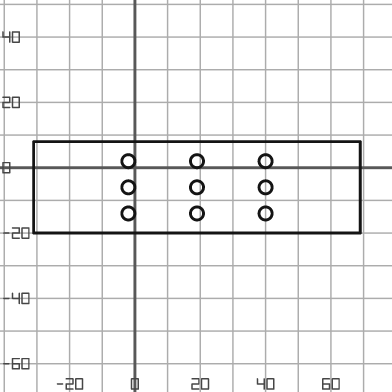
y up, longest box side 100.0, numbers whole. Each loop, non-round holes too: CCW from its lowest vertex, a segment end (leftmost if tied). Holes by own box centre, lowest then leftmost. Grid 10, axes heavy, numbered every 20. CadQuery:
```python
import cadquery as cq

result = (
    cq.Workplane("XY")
    .moveTo(-31.0, -20.0)
    .lineTo(69.0, -20.0)
    .lineTo(69.0, 8.0)
    .lineTo(-31.0, 8.0)
    .close()
    .moveTo(-2.0, -14.0)
    .circle(2.0)
    .moveTo(19.0, -14.0)
    .circle(2.0)
    .moveTo(40.0, -14.0)
    .circle(2.0)
    .moveTo(-2.0, -6.0)
    .circle(2.0)
    .moveTo(19.0, -6.0)
    .circle(2.0)
    .moveTo(40.0, -6.0)
    .circle(2.0)
    .moveTo(-2.0, 2.0)
    .circle(2.0)
    .moveTo(19.0, 2.0)
    .circle(2.0)
    .moveTo(40.0, 2.0)
    .circle(2.0)
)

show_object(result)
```